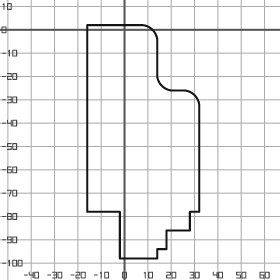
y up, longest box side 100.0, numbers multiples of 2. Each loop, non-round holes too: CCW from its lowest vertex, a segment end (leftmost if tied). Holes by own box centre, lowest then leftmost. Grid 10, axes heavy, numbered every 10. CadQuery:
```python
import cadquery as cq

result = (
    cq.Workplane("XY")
    .moveTo(-2.0, -98.0)
    .lineTo(14.0, -98.0)
    .lineTo(14.0, -94.0)
    .lineTo(18.0, -94.0)
    .lineTo(18.0, -86.0)
    .lineTo(28.0, -86.0)
    .lineTo(28.0, -78.0)
    .lineTo(32.0, -78.0)
    .lineTo(32.0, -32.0)
    .threePointArc((30.0, -28.0), (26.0, -26.0))
    .lineTo(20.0, -26.0)
    .threePointArc((16.0, -24.0), (14.0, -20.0))
    .lineTo(14.0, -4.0)
    .threePointArc((12.0, 0.0), (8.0, 2.0))
    .lineTo(-16.0, 2.0)
    .lineTo(-16.0, -78.0)
    .lineTo(-2.0, -78.0)
    .close()
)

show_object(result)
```